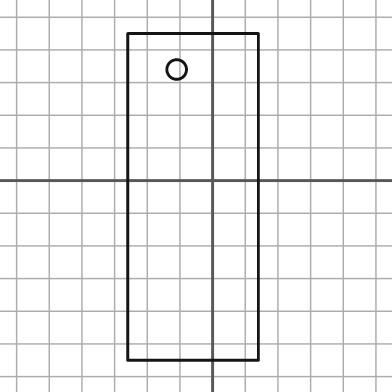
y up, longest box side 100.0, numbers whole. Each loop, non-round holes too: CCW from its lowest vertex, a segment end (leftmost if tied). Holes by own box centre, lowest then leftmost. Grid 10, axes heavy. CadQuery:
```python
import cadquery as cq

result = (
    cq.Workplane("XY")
    .moveTo(-26.0, -55.0)
    .lineTo(14.0, -55.0)
    .lineTo(14.0, 45.0)
    .lineTo(-26.0, 45.0)
    .close()
    .moveTo(-11.0, 34.0)
    .circle(3.0)
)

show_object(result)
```